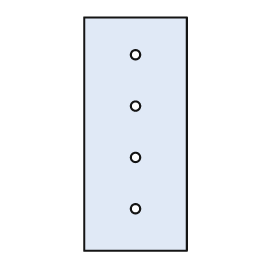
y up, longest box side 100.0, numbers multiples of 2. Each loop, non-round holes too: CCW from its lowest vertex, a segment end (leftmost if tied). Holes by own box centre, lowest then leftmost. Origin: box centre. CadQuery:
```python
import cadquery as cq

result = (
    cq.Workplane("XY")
    .moveTo(-22.0, -50.0)
    .lineTo(22.0, -50.0)
    .lineTo(22.0, 50.0)
    .lineTo(-22.0, 50.0)
    .close()
    .moveTo(0.0, -32.0)
    .circle(2.0)
    .moveTo(0.0, -10.0)
    .circle(2.0)
    .moveTo(0.0, 12.0)
    .circle(2.0)
    .moveTo(0.0, 34.0)
    .circle(2.0)
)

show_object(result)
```